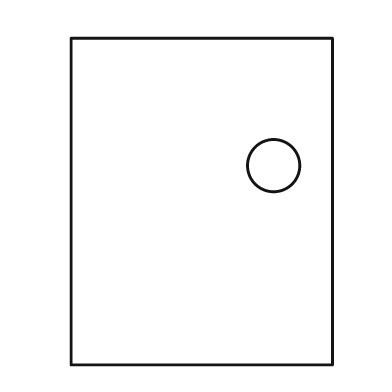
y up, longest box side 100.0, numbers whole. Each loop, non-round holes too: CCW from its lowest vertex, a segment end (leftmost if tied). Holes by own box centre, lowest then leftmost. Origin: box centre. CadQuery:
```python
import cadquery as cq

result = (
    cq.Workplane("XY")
    .moveTo(-40.0, -50.0)
    .lineTo(40.0, -50.0)
    .lineTo(40.0, 50.0)
    .lineTo(-40.0, 50.0)
    .close()
    .moveTo(22.0, 11.0)
    .circle(8.0)
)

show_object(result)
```